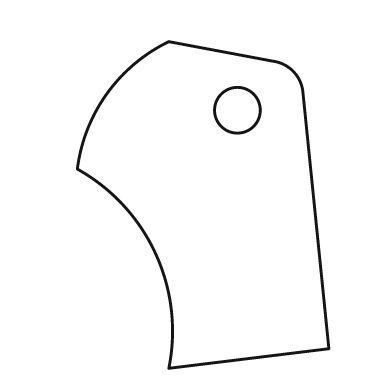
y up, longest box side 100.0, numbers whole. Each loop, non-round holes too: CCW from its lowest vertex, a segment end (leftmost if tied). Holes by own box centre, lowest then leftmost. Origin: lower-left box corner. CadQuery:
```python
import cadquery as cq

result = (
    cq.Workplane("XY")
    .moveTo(28.0, 0.0)
    .lineTo(77.0, 6.0)
    .lineTo(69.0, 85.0)
    .threePointArc((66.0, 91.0), (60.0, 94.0))
    .lineTo(28.0, 100.0)
    .threePointArc((9.0, 84.0), (0.0, 61.0))
    .threePointArc((24.0, 35.0), (28.0, 0.0))
    .close()
    .moveTo(49.0, 79.0)
    .circle(7.0)
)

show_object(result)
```